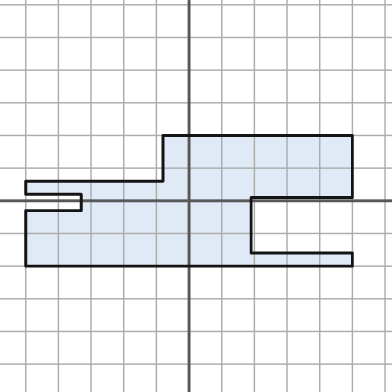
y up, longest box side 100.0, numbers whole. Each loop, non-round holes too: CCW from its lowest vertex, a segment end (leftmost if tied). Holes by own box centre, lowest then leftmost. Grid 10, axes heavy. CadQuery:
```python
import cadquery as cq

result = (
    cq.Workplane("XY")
    .moveTo(-50.0, -20.0)
    .lineTo(50.0, -20.0)
    .lineTo(50.0, -16.0)
    .lineTo(19.0, -16.0)
    .lineTo(19.0, 1.0)
    .lineTo(50.0, 1.0)
    .lineTo(50.0, 20.0)
    .lineTo(-8.0, 20.0)
    .lineTo(-8.0, 6.0)
    .lineTo(-50.0, 6.0)
    .lineTo(-50.0, 2.0)
    .lineTo(-33.0, 2.0)
    .lineTo(-33.0, -3.0)
    .lineTo(-50.0, -3.0)
    .close()
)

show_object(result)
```